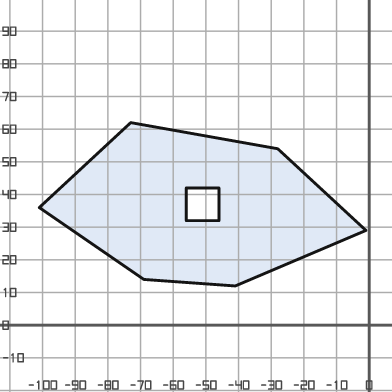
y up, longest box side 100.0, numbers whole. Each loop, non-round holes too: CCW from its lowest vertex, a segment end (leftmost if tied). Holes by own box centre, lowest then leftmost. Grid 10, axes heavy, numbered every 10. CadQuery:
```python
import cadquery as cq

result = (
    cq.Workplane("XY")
    .moveTo(-41.0, 12.0)
    .lineTo(-1.0, 29.0)
    .lineTo(-28.0, 54.0)
    .lineTo(-73.0, 62.0)
    .lineTo(-101.0, 36.0)
    .lineTo(-69.0, 14.0)
    .close()
    .moveTo(-56.0, 32.0)
    .lineTo(-46.0, 32.0)
    .lineTo(-46.0, 42.0)
    .lineTo(-56.0, 42.0)
    .close()
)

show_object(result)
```